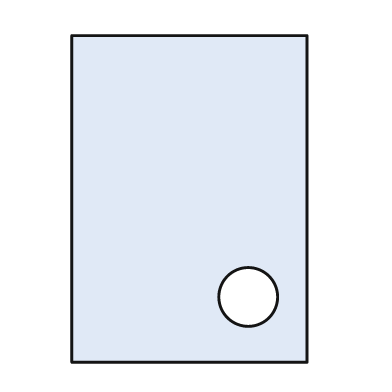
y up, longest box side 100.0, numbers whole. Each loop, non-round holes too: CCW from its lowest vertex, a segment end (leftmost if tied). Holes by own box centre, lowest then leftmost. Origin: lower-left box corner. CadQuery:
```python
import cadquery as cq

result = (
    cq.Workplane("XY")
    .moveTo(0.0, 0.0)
    .lineTo(72.0, 0.0)
    .lineTo(72.0, 100.0)
    .lineTo(0.0, 100.0)
    .close()
    .moveTo(54.0, 20.0)
    .circle(9.0)
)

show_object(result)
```